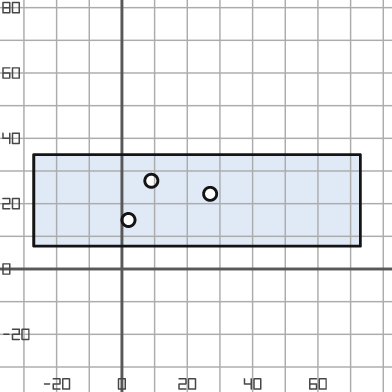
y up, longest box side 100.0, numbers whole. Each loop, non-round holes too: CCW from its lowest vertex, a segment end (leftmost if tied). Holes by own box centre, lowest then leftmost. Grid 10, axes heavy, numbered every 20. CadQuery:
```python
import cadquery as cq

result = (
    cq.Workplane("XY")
    .moveTo(-27.0, 7.0)
    .lineTo(73.0, 7.0)
    .lineTo(73.0, 35.0)
    .lineTo(-27.0, 35.0)
    .close()
    .moveTo(2.0, 15.0)
    .circle(2.0)
    .moveTo(27.0, 23.0)
    .circle(2.0)
    .moveTo(9.0, 27.0)
    .circle(2.0)
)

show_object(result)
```